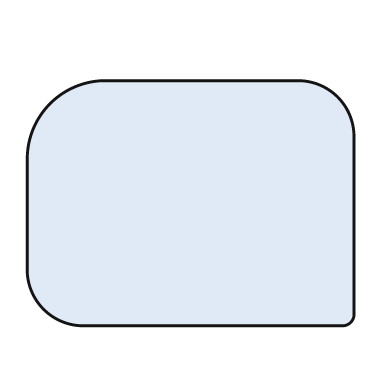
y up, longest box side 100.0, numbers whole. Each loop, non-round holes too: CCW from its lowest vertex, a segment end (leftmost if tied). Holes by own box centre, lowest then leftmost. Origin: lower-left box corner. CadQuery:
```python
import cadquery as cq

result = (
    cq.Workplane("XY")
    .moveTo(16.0, 0.0)
    .lineTo(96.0, 0.0)
    .threePointArc((99.0, 1.0), (100.0, 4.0))
    .lineTo(100.0, 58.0)
    .threePointArc((95.0, 70.0), (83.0, 75.0))
    .lineTo(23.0, 75.0)
    .threePointArc((7.0, 68.0), (0.0, 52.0))
    .lineTo(0.0, 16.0)
    .threePointArc((5.0, 5.0), (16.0, 0.0))
    .close()
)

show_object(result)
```